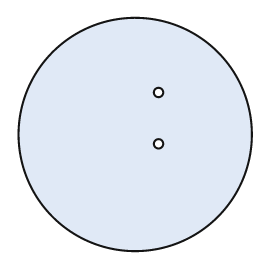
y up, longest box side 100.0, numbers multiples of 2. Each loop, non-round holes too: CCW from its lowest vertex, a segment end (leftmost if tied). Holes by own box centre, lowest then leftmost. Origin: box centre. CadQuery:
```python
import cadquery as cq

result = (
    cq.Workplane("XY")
    .moveTo(0.0, 0.0)
    .circle(50.0)
    .moveTo(10.0, -4.0)
    .circle(2.0)
    .moveTo(10.0, 18.0)
    .circle(2.0)
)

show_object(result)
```